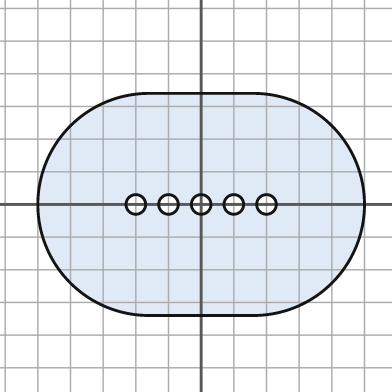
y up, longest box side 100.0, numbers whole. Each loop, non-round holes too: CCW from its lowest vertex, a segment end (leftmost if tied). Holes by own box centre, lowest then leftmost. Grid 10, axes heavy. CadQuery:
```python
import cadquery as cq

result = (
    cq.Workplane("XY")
    .moveTo(-16.0, -34.0)
    .lineTo(16.0, -34.0)
    .threePointArc((50.0, 0.0), (16.0, 34.0))
    .lineTo(-16.0, 34.0)
    .threePointArc((-50.0, 0.0), (-16.0, -34.0))
    .close()
    .moveTo(-20.0, 0.0)
    .circle(3.0)
    .moveTo(-10.0, 0.0)
    .circle(3.0)
    .moveTo(0.0, 0.0)
    .circle(3.0)
    .moveTo(10.0, 0.0)
    .circle(3.0)
    .moveTo(20.0, 0.0)
    .circle(3.0)
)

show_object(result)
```